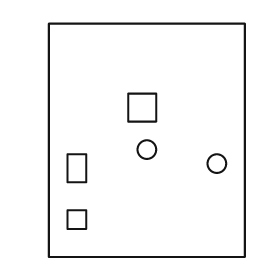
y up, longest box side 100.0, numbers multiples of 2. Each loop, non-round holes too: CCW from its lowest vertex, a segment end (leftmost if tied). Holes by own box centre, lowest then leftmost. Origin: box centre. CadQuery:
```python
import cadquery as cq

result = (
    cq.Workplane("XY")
    .moveTo(-42.0, -50.0)
    .lineTo(42.0, -50.0)
    .lineTo(42.0, 50.0)
    .lineTo(-42.0, 50.0)
    .close()
    .moveTo(-34.0, -38.0)
    .lineTo(-26.0, -38.0)
    .lineTo(-26.0, -30.0)
    .lineTo(-34.0, -30.0)
    .close()
    .moveTo(-34.0, -18.0)
    .lineTo(-26.0, -18.0)
    .lineTo(-26.0, -6.0)
    .lineTo(-34.0, -6.0)
    .close()
    .moveTo(30.0, -10.0)
    .circle(4.0)
    .moveTo(0.0, -4.0)
    .circle(4.0)
    .moveTo(-8.0, 8.0)
    .lineTo(4.0, 8.0)
    .lineTo(4.0, 20.0)
    .lineTo(-8.0, 20.0)
    .close()
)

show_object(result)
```